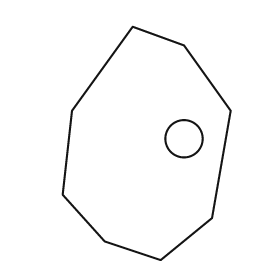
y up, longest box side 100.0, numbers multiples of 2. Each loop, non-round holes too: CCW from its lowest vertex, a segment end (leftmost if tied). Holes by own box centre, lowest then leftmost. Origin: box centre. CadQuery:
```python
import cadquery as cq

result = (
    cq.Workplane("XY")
    .moveTo(6.0, -50.0)
    .lineTo(28.0, -32.0)
    .lineTo(36.0, 14.0)
    .lineTo(16.0, 42.0)
    .lineTo(-6.0, 50.0)
    .lineTo(-32.0, 14.0)
    .lineTo(-36.0, -22.0)
    .lineTo(-18.0, -42.0)
    .close()
    .moveTo(16.0, 2.0)
    .circle(8.0)
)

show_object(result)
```